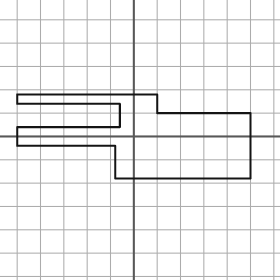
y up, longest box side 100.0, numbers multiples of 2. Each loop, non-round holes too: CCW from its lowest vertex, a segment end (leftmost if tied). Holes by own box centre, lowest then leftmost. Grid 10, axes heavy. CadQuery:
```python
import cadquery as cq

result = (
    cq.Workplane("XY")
    .moveTo(-8.0, -18.0)
    .lineTo(50.0, -18.0)
    .lineTo(50.0, 10.0)
    .lineTo(10.0, 10.0)
    .lineTo(10.0, 18.0)
    .lineTo(-50.0, 18.0)
    .lineTo(-50.0, 14.0)
    .lineTo(-6.0, 14.0)
    .lineTo(-6.0, 4.0)
    .lineTo(-50.0, 4.0)
    .lineTo(-50.0, -4.0)
    .lineTo(-8.0, -4.0)
    .close()
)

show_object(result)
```